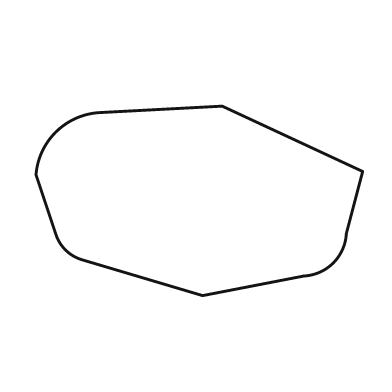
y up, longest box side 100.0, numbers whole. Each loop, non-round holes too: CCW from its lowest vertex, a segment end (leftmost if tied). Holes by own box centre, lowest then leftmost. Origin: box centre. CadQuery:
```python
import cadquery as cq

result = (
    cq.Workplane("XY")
    .moveTo(1.0, -29.0)
    .lineTo(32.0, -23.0)
    .threePointArc((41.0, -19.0), (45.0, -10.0))
    .lineTo(50.0, 9.0)
    .lineTo(7.0, 29.0)
    .lineTo(-31.0, 27.0)
    .threePointArc((-44.0, 21.0), (-50.0, 8.0))
    .lineTo(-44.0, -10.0)
    .threePointArc((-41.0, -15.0), (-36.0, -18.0))
    .close()
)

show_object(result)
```